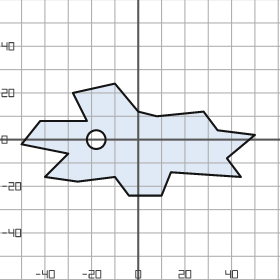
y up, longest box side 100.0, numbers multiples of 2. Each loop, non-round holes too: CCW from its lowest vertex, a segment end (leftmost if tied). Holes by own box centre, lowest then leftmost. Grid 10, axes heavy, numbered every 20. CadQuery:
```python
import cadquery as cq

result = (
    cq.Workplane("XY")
    .moveTo(-4.0, -24.0)
    .lineTo(10.0, -24.0)
    .lineTo(14.0, -14.0)
    .lineTo(44.0, -16.0)
    .lineTo(38.0, -8.0)
    .lineTo(50.0, 2.0)
    .lineTo(34.0, 4.0)
    .lineTo(28.0, 12.0)
    .lineTo(8.0, 10.0)
    .lineTo(0.0, 12.0)
    .lineTo(-10.0, 24.0)
    .lineTo(-28.0, 20.0)
    .lineTo(-22.0, 8.0)
    .lineTo(-42.0, 8.0)
    .lineTo(-50.0, -2.0)
    .lineTo(-30.0, -6.0)
    .lineTo(-40.0, -16.0)
    .lineTo(-26.0, -18.0)
    .lineTo(-10.0, -16.0)
    .close()
    .moveTo(-18.0, 0.0)
    .circle(4.0)
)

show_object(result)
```